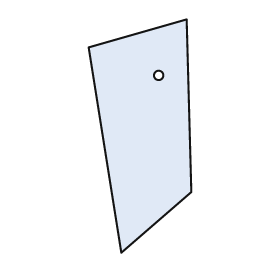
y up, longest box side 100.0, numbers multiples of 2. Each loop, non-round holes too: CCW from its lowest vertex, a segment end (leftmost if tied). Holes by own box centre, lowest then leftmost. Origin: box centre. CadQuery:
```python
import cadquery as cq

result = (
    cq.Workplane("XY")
    .moveTo(-8.0, -50.0)
    .lineTo(22.0, -24.0)
    .lineTo(20.0, 50.0)
    .lineTo(-22.0, 38.0)
    .close()
    .moveTo(8.0, 26.0)
    .circle(2.0)
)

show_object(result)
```